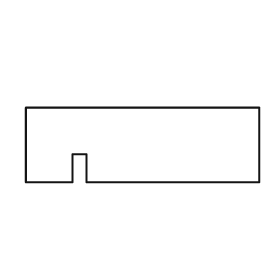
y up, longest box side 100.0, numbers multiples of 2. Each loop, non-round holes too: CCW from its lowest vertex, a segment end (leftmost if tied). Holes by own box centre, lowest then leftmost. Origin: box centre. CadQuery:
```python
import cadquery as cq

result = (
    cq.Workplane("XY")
    .moveTo(-50.0, -16.0)
    .lineTo(-30.0, -16.0)
    .lineTo(-30.0, -4.0)
    .lineTo(-24.0, -4.0)
    .lineTo(-24.0, -16.0)
    .lineTo(50.0, -16.0)
    .lineTo(50.0, 16.0)
    .lineTo(-50.0, 16.0)
    .close()
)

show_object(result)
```